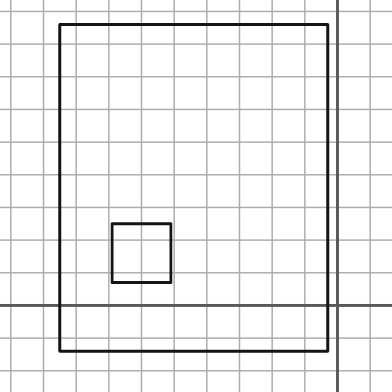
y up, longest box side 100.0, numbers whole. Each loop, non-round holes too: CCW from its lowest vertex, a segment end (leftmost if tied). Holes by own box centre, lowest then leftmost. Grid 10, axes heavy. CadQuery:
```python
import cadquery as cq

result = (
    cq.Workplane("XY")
    .moveTo(-85.0, -14.0)
    .lineTo(-3.0, -14.0)
    .lineTo(-3.0, 86.0)
    .lineTo(-85.0, 86.0)
    .close()
    .moveTo(-69.0, 7.0)
    .lineTo(-51.0, 7.0)
    .lineTo(-51.0, 25.0)
    .lineTo(-69.0, 25.0)
    .close()
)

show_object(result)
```